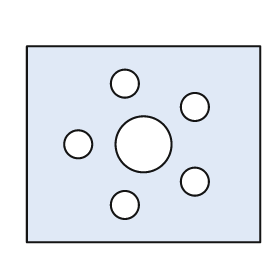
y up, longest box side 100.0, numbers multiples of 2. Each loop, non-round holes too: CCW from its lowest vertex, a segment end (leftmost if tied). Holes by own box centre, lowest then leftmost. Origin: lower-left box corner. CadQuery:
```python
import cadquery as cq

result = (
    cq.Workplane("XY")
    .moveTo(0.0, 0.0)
    .lineTo(100.0, 0.0)
    .lineTo(100.0, 84.0)
    .lineTo(0.0, 84.0)
    .close()
    .moveTo(42.0, 16.0)
    .circle(6.0)
    .moveTo(72.0, 26.0)
    .circle(6.0)
    .moveTo(22.0, 42.0)
    .circle(6.0)
    .moveTo(50.0, 42.0)
    .circle(12.0)
    .moveTo(72.0, 58.0)
    .circle(6.0)
    .moveTo(42.0, 68.0)
    .circle(6.0)
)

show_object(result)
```